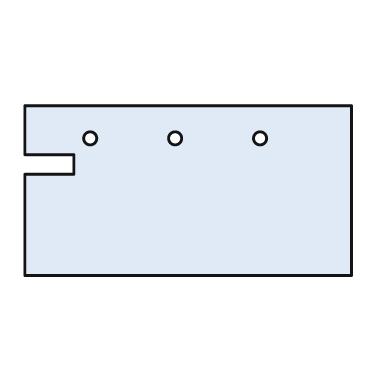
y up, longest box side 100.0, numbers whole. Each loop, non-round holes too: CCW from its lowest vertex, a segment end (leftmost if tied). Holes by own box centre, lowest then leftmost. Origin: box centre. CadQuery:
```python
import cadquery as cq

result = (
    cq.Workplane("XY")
    .moveTo(-50.0, -26.0)
    .lineTo(50.0, -26.0)
    .lineTo(50.0, 26.0)
    .lineTo(-50.0, 26.0)
    .lineTo(-50.0, 11.0)
    .lineTo(-35.0, 11.0)
    .lineTo(-35.0, 5.0)
    .lineTo(-50.0, 5.0)
    .close()
    .moveTo(-30.0, 16.0)
    .circle(2.0)
    .moveTo(-4.0, 16.0)
    .circle(2.0)
    .moveTo(22.0, 16.0)
    .circle(2.0)
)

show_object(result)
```